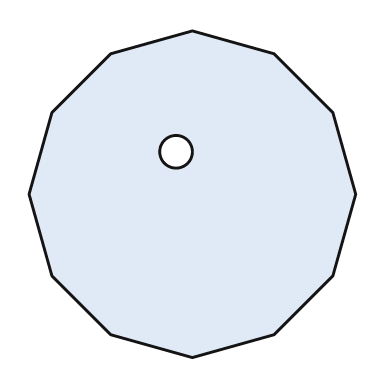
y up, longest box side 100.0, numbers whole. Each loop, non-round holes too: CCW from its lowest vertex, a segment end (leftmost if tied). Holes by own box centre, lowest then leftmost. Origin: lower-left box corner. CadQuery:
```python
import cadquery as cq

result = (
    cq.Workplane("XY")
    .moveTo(50.0, 0.0)
    .lineTo(75.0, 7.0)
    .lineTo(93.0, 25.0)
    .lineTo(100.0, 50.0)
    .lineTo(93.0, 75.0)
    .lineTo(75.0, 93.0)
    .lineTo(50.0, 100.0)
    .lineTo(25.0, 93.0)
    .lineTo(7.0, 75.0)
    .lineTo(0.0, 50.0)
    .lineTo(7.0, 25.0)
    .lineTo(25.0, 7.0)
    .close()
    .moveTo(45.0, 63.0)
    .circle(5.0)
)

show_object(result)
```